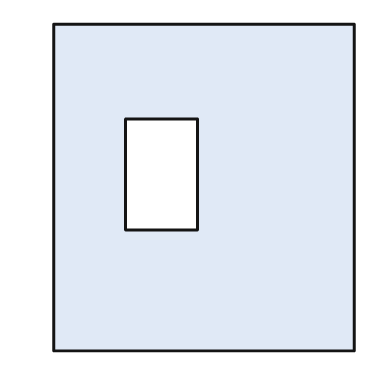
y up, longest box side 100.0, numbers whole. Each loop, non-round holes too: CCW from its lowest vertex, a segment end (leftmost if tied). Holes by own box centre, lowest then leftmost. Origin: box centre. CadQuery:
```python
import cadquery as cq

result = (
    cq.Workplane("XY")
    .moveTo(-46.0, -50.0)
    .lineTo(46.0, -50.0)
    .lineTo(46.0, 50.0)
    .lineTo(-46.0, 50.0)
    .close()
    .moveTo(-24.0, -13.0)
    .lineTo(-2.0, -13.0)
    .lineTo(-2.0, 21.0)
    .lineTo(-24.0, 21.0)
    .close()
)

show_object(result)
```